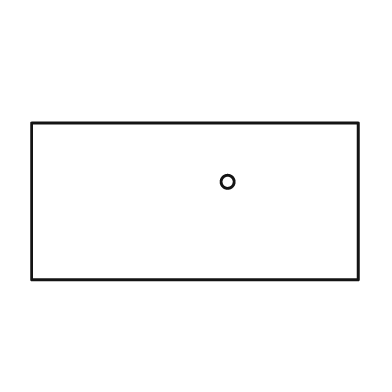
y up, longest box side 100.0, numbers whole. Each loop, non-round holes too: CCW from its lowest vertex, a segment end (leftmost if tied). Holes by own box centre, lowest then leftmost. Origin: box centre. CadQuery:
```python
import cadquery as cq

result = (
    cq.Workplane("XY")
    .moveTo(-50.0, -24.0)
    .lineTo(50.0, -24.0)
    .lineTo(50.0, 24.0)
    .lineTo(-50.0, 24.0)
    .close()
    .moveTo(10.0, 6.0)
    .circle(2.0)
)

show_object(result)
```